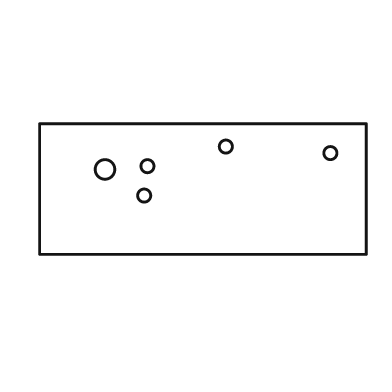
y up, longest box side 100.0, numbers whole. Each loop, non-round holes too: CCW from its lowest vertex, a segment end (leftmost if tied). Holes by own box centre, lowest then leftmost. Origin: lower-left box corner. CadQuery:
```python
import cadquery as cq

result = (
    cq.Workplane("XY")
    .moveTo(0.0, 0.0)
    .lineTo(100.0, 0.0)
    .lineTo(100.0, 40.0)
    .lineTo(0.0, 40.0)
    .close()
    .moveTo(32.0, 18.0)
    .circle(2.0)
    .moveTo(20.0, 26.0)
    .circle(3.0)
    .moveTo(33.0, 27.0)
    .circle(2.0)
    .moveTo(89.0, 31.0)
    .circle(2.0)
    .moveTo(57.0, 33.0)
    .circle(2.0)
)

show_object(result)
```